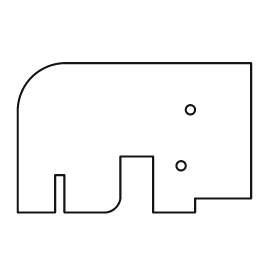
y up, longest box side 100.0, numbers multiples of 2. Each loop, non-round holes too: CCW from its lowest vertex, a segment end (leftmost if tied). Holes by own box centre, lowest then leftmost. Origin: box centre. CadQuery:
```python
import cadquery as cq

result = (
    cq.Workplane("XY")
    .moveTo(-50.0, -32.0)
    .lineTo(-34.0, -32.0)
    .lineTo(-34.0, -16.0)
    .lineTo(-30.0, -16.0)
    .lineTo(-30.0, -32.0)
    .lineTo(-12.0, -32.0)
    .threePointArc((-8.0, -30.0), (-6.0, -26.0))
    .lineTo(-6.0, -8.0)
    .lineTo(8.0, -8.0)
    .lineTo(8.0, -32.0)
    .lineTo(26.0, -32.0)
    .lineTo(26.0, -26.0)
    .lineTo(50.0, -26.0)
    .lineTo(50.0, 32.0)
    .lineTo(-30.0, 32.0)
    .threePointArc((-44.0, 26.0), (-50.0, 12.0))
    .close()
    .moveTo(20.0, -12.0)
    .circle(2.0)
    .moveTo(24.0, 12.0)
    .circle(2.0)
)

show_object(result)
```